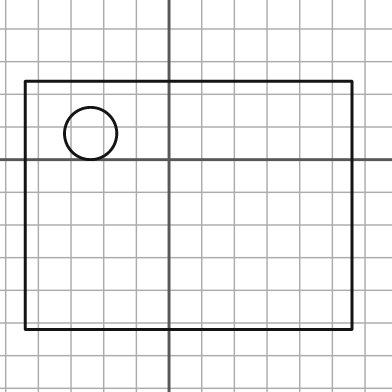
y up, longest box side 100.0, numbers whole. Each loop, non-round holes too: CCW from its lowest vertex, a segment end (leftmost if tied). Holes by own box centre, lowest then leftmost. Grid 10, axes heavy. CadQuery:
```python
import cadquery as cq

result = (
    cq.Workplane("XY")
    .moveTo(-44.0, -52.0)
    .lineTo(56.0, -52.0)
    .lineTo(56.0, 24.0)
    .lineTo(-44.0, 24.0)
    .close()
    .moveTo(-24.0, 8.0)
    .circle(8.0)
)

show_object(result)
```